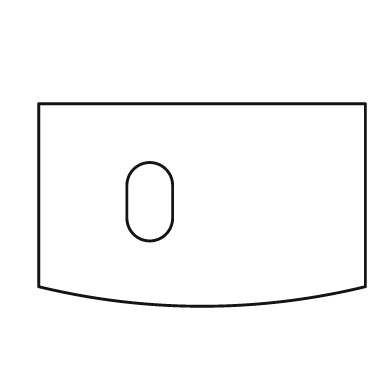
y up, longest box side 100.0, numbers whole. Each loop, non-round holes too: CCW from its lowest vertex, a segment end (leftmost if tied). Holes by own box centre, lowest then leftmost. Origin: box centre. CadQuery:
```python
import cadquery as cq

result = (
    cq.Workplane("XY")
    .moveTo(-50.0, -25.0)
    .threePointArc((0.0, -31.0), (50.0, -25.0))
    .lineTo(50.0, 31.0)
    .lineTo(-50.0, 31.0)
    .close()
    .moveTo(-23.0, -4.0)
    .threePointArc((-16.0, -11.0), (-9.0, -4.0))
    .lineTo(-9.0, 6.0)
    .threePointArc((-16.0, 13.0), (-23.0, 6.0))
    .close()
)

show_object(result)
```